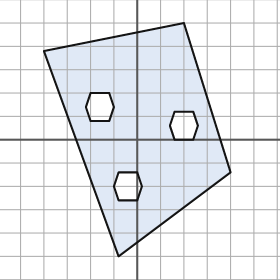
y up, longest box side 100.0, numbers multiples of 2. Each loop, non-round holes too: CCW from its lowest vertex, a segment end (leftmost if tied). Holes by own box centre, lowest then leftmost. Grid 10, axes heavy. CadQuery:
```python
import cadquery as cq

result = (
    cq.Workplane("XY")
    .moveTo(-8.0, -50.0)
    .lineTo(40.0, -14.0)
    .lineTo(20.0, 50.0)
    .lineTo(-40.0, 38.0)
    .close()
    .moveTo(-8.0, -26.0)
    .lineTo(0.0, -26.0)
    .lineTo(2.0, -20.0)
    .lineTo(0.0, -14.0)
    .lineTo(-8.0, -14.0)
    .lineTo(-10.0, -20.0)
    .close()
    .moveTo(16.0, 0.0)
    .lineTo(24.0, 0.0)
    .lineTo(26.0, 6.0)
    .lineTo(24.0, 12.0)
    .lineTo(16.0, 12.0)
    .lineTo(14.0, 6.0)
    .close()
    .moveTo(-20.0, 8.0)
    .lineTo(-12.0, 8.0)
    .lineTo(-10.0, 14.0)
    .lineTo(-12.0, 20.0)
    .lineTo(-20.0, 20.0)
    .lineTo(-22.0, 14.0)
    .close()
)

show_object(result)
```